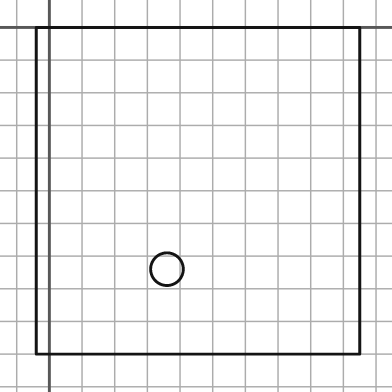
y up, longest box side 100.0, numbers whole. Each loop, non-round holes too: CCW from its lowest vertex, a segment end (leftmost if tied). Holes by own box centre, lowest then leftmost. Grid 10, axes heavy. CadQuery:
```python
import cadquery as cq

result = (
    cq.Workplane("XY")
    .moveTo(-4.0, -100.0)
    .lineTo(95.0, -100.0)
    .lineTo(95.0, 0.0)
    .lineTo(-4.0, 0.0)
    .close()
    .moveTo(36.0, -74.0)
    .circle(5.0)
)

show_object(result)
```